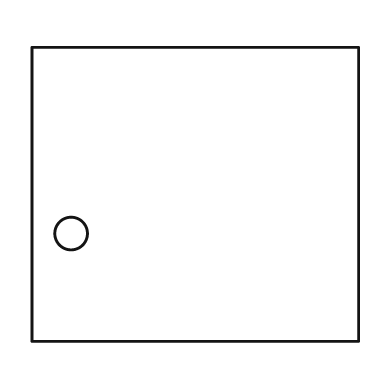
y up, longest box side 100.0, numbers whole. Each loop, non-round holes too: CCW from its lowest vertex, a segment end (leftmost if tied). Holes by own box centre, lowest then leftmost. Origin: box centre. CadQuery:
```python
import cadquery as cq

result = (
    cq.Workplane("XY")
    .moveTo(-50.0, -45.0)
    .lineTo(50.0, -45.0)
    .lineTo(50.0, 45.0)
    .lineTo(-50.0, 45.0)
    .close()
    .moveTo(-38.0, -12.0)
    .circle(5.0)
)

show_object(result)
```